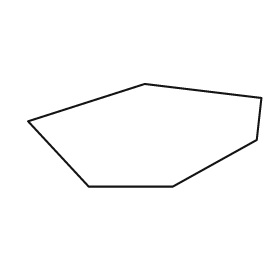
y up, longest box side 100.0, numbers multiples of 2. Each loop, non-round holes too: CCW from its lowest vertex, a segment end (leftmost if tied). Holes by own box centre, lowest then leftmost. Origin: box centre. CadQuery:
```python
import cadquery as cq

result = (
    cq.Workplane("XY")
    .moveTo(-24.0, -22.0)
    .lineTo(12.0, -22.0)
    .lineTo(48.0, -2.0)
    .lineTo(50.0, 16.0)
    .lineTo(0.0, 22.0)
    .lineTo(-50.0, 6.0)
    .close()
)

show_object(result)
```